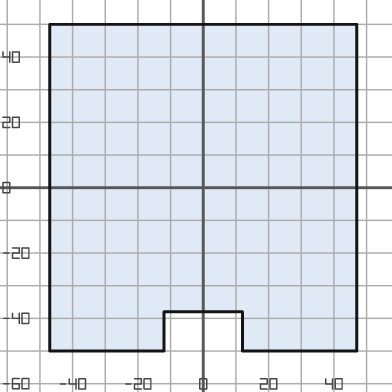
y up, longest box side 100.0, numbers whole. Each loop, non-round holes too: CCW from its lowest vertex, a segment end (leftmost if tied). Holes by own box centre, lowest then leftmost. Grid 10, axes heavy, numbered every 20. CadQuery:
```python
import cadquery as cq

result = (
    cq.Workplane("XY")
    .moveTo(-47.0, -50.0)
    .lineTo(-12.0, -50.0)
    .lineTo(-12.0, -38.0)
    .lineTo(12.0, -38.0)
    .lineTo(12.0, -50.0)
    .lineTo(47.0, -50.0)
    .lineTo(47.0, 50.0)
    .lineTo(-47.0, 50.0)
    .close()
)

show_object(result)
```